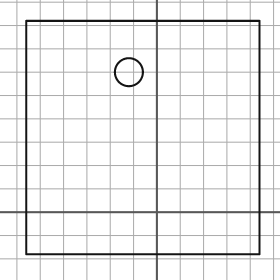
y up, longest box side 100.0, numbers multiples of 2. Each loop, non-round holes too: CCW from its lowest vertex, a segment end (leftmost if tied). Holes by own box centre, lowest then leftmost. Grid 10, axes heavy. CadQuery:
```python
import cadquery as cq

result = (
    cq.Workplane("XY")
    .moveTo(-56.0, -18.0)
    .lineTo(44.0, -18.0)
    .lineTo(44.0, 82.0)
    .lineTo(-56.0, 82.0)
    .close()
    .moveTo(-12.0, 60.0)
    .circle(6.0)
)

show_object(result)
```